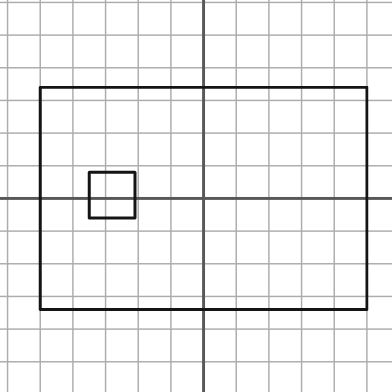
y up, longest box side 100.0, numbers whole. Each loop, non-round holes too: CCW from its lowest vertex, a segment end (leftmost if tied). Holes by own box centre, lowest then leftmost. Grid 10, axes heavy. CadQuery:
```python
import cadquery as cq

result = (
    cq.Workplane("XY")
    .moveTo(-50.0, -34.0)
    .lineTo(50.0, -34.0)
    .lineTo(50.0, 34.0)
    .lineTo(-50.0, 34.0)
    .close()
    .moveTo(-35.0, -6.0)
    .lineTo(-21.0, -6.0)
    .lineTo(-21.0, 8.0)
    .lineTo(-35.0, 8.0)
    .close()
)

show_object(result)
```